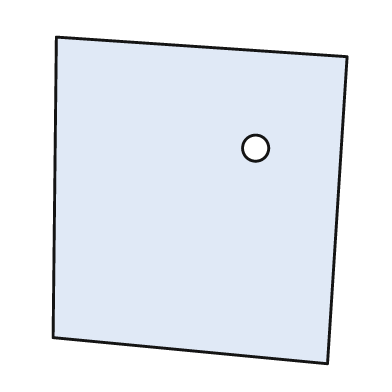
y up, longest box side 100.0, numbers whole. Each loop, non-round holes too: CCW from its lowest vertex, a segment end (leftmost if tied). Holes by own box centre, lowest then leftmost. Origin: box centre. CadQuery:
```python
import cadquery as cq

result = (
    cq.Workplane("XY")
    .moveTo(39.0, -50.0)
    .lineTo(45.0, 44.0)
    .lineTo(-44.0, 50.0)
    .lineTo(-45.0, -42.0)
    .close()
    .moveTo(17.0, 16.0)
    .circle(4.0)
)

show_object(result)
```